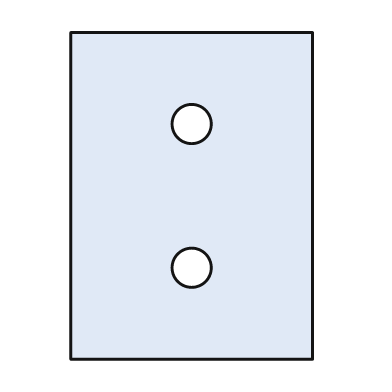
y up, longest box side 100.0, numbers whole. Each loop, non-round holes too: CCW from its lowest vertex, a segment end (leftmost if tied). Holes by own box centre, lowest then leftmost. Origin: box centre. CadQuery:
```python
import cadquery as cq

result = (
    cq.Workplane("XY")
    .moveTo(-37.0, -50.0)
    .lineTo(37.0, -50.0)
    .lineTo(37.0, 50.0)
    .lineTo(-37.0, 50.0)
    .close()
    .moveTo(0.0, -22.0)
    .circle(6.0)
    .moveTo(0.0, 22.0)
    .circle(6.0)
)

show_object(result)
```